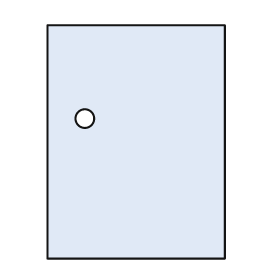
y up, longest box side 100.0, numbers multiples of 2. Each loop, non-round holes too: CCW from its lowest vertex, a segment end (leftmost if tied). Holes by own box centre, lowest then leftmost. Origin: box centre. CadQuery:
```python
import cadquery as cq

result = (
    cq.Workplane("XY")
    .moveTo(-38.0, -50.0)
    .lineTo(38.0, -50.0)
    .lineTo(38.0, 50.0)
    .lineTo(-38.0, 50.0)
    .close()
    .moveTo(-22.0, 10.0)
    .circle(4.0)
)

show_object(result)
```